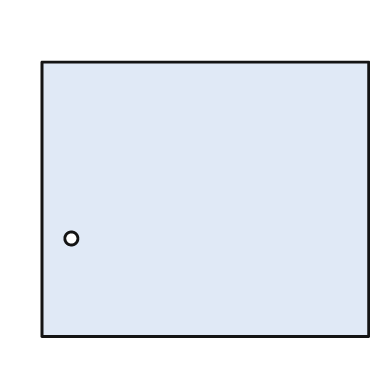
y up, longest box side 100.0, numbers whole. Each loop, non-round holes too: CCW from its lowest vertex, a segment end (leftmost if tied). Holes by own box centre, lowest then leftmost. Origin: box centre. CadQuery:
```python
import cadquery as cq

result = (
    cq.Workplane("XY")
    .moveTo(-50.0, -42.0)
    .lineTo(50.0, -42.0)
    .lineTo(50.0, 42.0)
    .lineTo(-50.0, 42.0)
    .close()
    .moveTo(-41.0, -12.0)
    .circle(2.0)
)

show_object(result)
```